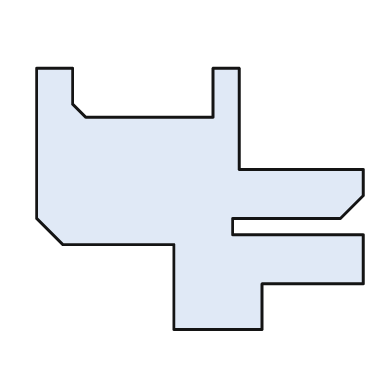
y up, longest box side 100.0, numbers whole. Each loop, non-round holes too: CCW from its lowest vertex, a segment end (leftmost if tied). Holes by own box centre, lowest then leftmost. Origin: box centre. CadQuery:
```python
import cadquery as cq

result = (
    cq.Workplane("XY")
    .moveTo(-8.0, -40.0)
    .lineTo(19.0, -40.0)
    .lineTo(19.0, -26.0)
    .lineTo(50.0, -26.0)
    .lineTo(50.0, -11.0)
    .lineTo(10.0, -11.0)
    .lineTo(10.0, -6.0)
    .lineTo(43.0, -6.0)
    .lineTo(50.0, 1.0)
    .lineTo(50.0, 9.0)
    .lineTo(12.0, 9.0)
    .lineTo(12.0, 40.0)
    .lineTo(4.0, 40.0)
    .lineTo(4.0, 25.0)
    .lineTo(-35.0, 25.0)
    .lineTo(-39.0, 29.0)
    .lineTo(-39.0, 40.0)
    .lineTo(-50.0, 40.0)
    .lineTo(-50.0, -6.0)
    .lineTo(-42.0, -14.0)
    .lineTo(-8.0, -14.0)
    .close()
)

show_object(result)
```